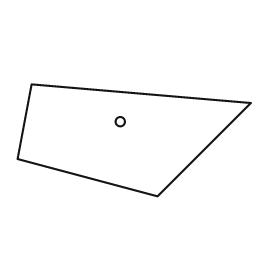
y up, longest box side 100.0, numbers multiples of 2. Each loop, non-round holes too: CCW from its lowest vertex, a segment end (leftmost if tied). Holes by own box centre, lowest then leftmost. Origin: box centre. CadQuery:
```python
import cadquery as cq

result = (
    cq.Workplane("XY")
    .moveTo(10.0, -24.0)
    .lineTo(50.0, 16.0)
    .lineTo(-44.0, 24.0)
    .lineTo(-50.0, -8.0)
    .close()
    .moveTo(-6.0, 8.0)
    .circle(2.0)
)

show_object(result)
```